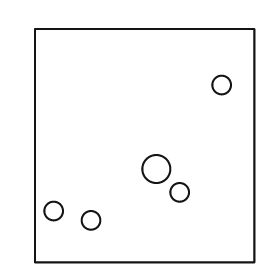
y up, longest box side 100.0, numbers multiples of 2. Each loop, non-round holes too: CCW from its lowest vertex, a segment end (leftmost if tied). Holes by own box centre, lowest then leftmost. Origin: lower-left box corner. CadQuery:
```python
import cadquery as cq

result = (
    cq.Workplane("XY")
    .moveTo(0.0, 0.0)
    .lineTo(94.0, 0.0)
    .lineTo(94.0, 100.0)
    .lineTo(0.0, 100.0)
    .close()
    .moveTo(24.0, 18.0)
    .circle(4.0)
    .moveTo(8.0, 22.0)
    .circle(4.0)
    .moveTo(62.0, 30.0)
    .circle(4.0)
    .moveTo(52.0, 40.0)
    .circle(6.0)
    .moveTo(80.0, 76.0)
    .circle(4.0)
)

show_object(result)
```